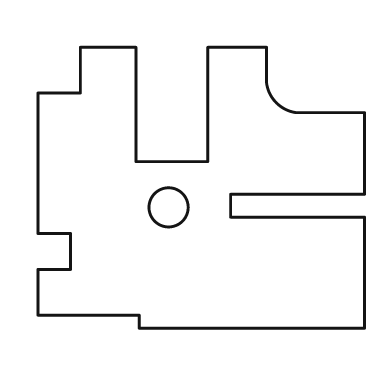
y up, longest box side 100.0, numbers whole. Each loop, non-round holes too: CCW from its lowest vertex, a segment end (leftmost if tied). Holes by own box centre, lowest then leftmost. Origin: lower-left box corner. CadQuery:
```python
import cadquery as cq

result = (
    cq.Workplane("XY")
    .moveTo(31.0, 0.0)
    .lineTo(100.0, 0.0)
    .lineTo(100.0, 34.0)
    .lineTo(59.0, 34.0)
    .lineTo(59.0, 41.0)
    .lineTo(100.0, 41.0)
    .lineTo(100.0, 66.0)
    .lineTo(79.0, 66.0)
    .threePointArc((73.0, 69.0), (70.0, 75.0))
    .lineTo(70.0, 86.0)
    .lineTo(52.0, 86.0)
    .lineTo(52.0, 51.0)
    .lineTo(30.0, 51.0)
    .lineTo(30.0, 86.0)
    .lineTo(13.0, 86.0)
    .lineTo(13.0, 72.0)
    .lineTo(0.0, 72.0)
    .lineTo(0.0, 29.0)
    .lineTo(10.0, 29.0)
    .lineTo(10.0, 18.0)
    .lineTo(0.0, 18.0)
    .lineTo(0.0, 4.0)
    .lineTo(31.0, 4.0)
    .close()
    .moveTo(40.0, 37.0)
    .circle(6.0)
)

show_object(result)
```